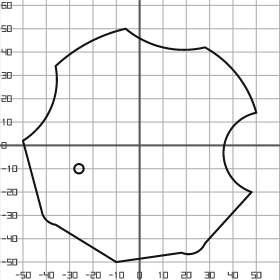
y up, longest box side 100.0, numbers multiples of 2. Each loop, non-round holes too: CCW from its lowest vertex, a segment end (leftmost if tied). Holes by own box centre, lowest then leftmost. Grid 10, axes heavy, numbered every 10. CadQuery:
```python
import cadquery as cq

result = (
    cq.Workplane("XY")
    .moveTo(-10.0, -50.0)
    .lineTo(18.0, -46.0)
    .threePointArc((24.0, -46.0), (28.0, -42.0))
    .lineTo(48.0, -20.0)
    .threePointArc((36.0, -2.0), (50.0, 14.0))
    .threePointArc((42.0, 30.0), (28.0, 42.0))
    .threePointArc((10.0, 42.0), (-6.0, 50.0))
    .threePointArc((-22.0, 44.0), (-36.0, 34.0))
    .threePointArc((-38.0, 16.0), (-50.0, 2.0))
    .lineTo(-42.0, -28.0)
    .threePointArc((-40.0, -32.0), (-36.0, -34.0))
    .close()
    .moveTo(-26.0, -10.0)
    .circle(2.0)
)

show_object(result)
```